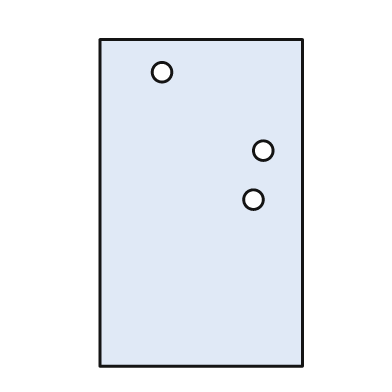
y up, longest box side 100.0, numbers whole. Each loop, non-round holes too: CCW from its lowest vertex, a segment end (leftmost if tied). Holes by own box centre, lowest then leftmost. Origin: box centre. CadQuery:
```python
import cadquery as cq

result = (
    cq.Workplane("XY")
    .moveTo(-31.0, -50.0)
    .lineTo(31.0, -50.0)
    .lineTo(31.0, 50.0)
    .lineTo(-31.0, 50.0)
    .close()
    .moveTo(16.0, 1.0)
    .circle(3.0)
    .moveTo(19.0, 16.0)
    .circle(3.0)
    .moveTo(-12.0, 40.0)
    .circle(3.0)
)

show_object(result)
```